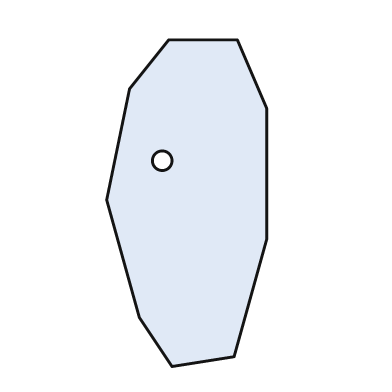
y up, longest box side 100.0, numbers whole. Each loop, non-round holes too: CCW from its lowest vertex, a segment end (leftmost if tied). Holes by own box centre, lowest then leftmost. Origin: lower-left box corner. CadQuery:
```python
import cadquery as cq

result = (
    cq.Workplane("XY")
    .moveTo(20.0, 0.0)
    .lineTo(39.0, 3.0)
    .lineTo(49.0, 39.0)
    .lineTo(49.0, 79.0)
    .lineTo(40.0, 100.0)
    .lineTo(19.0, 100.0)
    .lineTo(7.0, 85.0)
    .lineTo(0.0, 51.0)
    .lineTo(10.0, 15.0)
    .close()
    .moveTo(17.0, 63.0)
    .circle(3.0)
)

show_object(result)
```